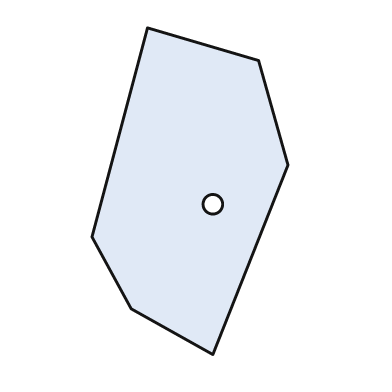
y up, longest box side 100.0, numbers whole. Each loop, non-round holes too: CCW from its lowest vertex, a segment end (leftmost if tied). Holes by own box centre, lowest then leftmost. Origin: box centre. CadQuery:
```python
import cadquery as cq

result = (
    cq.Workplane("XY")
    .moveTo(7.0, -50.0)
    .lineTo(30.0, 8.0)
    .lineTo(21.0, 40.0)
    .lineTo(-13.0, 50.0)
    .lineTo(-30.0, -14.0)
    .lineTo(-18.0, -36.0)
    .close()
    .moveTo(7.0, -4.0)
    .circle(3.0)
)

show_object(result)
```